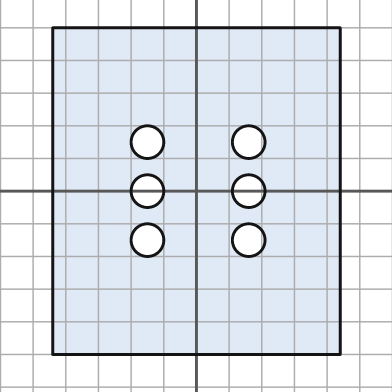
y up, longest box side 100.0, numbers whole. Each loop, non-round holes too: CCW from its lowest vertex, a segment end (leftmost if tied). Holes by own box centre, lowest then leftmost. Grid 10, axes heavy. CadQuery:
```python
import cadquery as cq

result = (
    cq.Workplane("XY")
    .moveTo(-44.0, -50.0)
    .lineTo(44.0, -50.0)
    .lineTo(44.0, 50.0)
    .lineTo(-44.0, 50.0)
    .close()
    .moveTo(-15.0, -15.0)
    .circle(5.0)
    .moveTo(16.0, -15.0)
    .circle(5.0)
    .moveTo(-15.0, 0.0)
    .circle(5.0)
    .moveTo(16.0, 0.0)
    .circle(5.0)
    .moveTo(-15.0, 15.0)
    .circle(5.0)
    .moveTo(16.0, 15.0)
    .circle(5.0)
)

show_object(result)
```